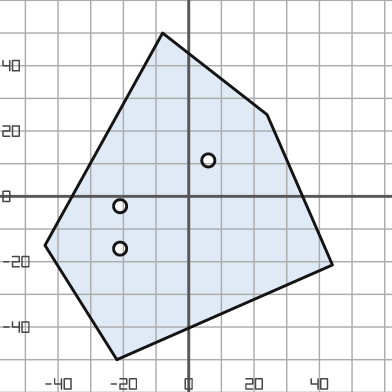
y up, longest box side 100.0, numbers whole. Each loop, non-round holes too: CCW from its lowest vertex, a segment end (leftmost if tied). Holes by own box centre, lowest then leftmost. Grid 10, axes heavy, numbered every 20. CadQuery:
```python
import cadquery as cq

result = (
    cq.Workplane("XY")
    .moveTo(-22.0, -50.0)
    .lineTo(44.0, -21.0)
    .lineTo(24.0, 25.0)
    .lineTo(-8.0, 50.0)
    .lineTo(-44.0, -15.0)
    .close()
    .moveTo(-21.0, -16.0)
    .circle(2.0)
    .moveTo(-21.0, -3.0)
    .circle(2.0)
    .moveTo(6.0, 11.0)
    .circle(2.0)
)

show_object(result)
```